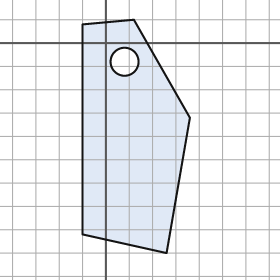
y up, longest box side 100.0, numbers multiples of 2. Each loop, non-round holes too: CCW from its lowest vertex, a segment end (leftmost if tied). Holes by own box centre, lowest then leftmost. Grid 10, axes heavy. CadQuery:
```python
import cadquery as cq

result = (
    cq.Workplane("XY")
    .moveTo(26.0, -90.0)
    .lineTo(36.0, -32.0)
    .lineTo(12.0, 10.0)
    .lineTo(-10.0, 8.0)
    .lineTo(-10.0, -82.0)
    .close()
    .moveTo(8.0, -8.0)
    .circle(6.0)
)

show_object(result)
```